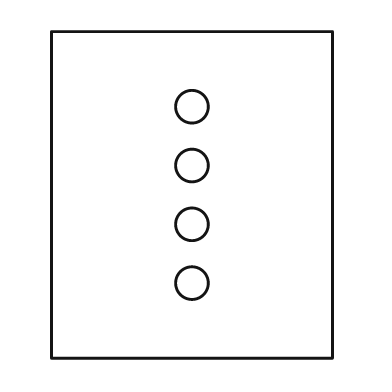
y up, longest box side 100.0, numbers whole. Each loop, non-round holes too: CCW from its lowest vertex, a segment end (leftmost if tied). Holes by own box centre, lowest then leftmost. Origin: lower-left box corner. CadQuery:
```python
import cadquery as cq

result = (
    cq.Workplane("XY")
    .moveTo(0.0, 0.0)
    .lineTo(86.0, 0.0)
    .lineTo(86.0, 100.0)
    .lineTo(0.0, 100.0)
    .close()
    .moveTo(43.0, 23.0)
    .circle(5.0)
    .moveTo(43.0, 41.0)
    .circle(5.0)
    .moveTo(43.0, 59.0)
    .circle(5.0)
    .moveTo(43.0, 77.0)
    .circle(5.0)
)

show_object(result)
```